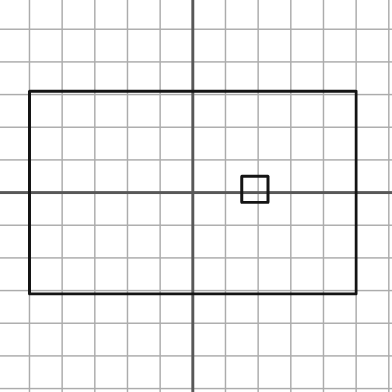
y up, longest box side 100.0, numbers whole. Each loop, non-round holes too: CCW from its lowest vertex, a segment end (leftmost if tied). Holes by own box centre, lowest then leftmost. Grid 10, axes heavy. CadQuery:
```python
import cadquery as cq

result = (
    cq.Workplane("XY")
    .moveTo(-50.0, -31.0)
    .lineTo(50.0, -31.0)
    .lineTo(50.0, 31.0)
    .lineTo(-50.0, 31.0)
    .close()
    .moveTo(15.0, -3.0)
    .lineTo(23.0, -3.0)
    .lineTo(23.0, 5.0)
    .lineTo(15.0, 5.0)
    .close()
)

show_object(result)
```